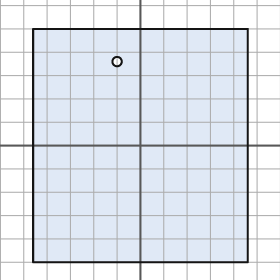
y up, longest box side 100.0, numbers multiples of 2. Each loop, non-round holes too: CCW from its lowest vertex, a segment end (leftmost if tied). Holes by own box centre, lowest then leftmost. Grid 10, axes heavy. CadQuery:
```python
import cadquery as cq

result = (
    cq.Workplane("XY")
    .moveTo(-46.0, -50.0)
    .lineTo(46.0, -50.0)
    .lineTo(46.0, 50.0)
    .lineTo(-46.0, 50.0)
    .close()
    .moveTo(-10.0, 36.0)
    .circle(2.0)
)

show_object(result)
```